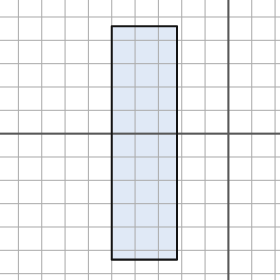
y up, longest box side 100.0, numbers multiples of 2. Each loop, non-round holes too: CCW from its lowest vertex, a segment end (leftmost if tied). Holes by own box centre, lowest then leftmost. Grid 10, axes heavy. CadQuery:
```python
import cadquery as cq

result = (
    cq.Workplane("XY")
    .moveTo(-50.0, -54.0)
    .lineTo(-22.0, -54.0)
    .lineTo(-22.0, 46.0)
    .lineTo(-50.0, 46.0)
    .close()
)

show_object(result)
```